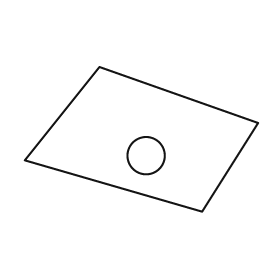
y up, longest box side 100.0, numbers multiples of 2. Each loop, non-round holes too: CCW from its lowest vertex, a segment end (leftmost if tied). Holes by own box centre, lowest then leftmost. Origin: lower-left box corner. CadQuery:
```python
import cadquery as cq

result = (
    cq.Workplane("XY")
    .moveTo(76.0, 0.0)
    .lineTo(100.0, 38.0)
    .lineTo(32.0, 62.0)
    .lineTo(0.0, 22.0)
    .close()
    .moveTo(52.0, 24.0)
    .circle(8.0)
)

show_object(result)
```